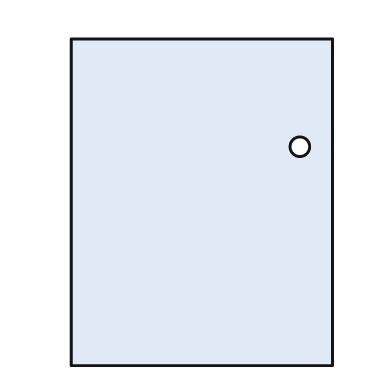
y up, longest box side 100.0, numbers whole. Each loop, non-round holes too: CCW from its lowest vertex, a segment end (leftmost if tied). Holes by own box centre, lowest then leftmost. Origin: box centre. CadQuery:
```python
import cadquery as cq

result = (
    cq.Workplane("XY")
    .moveTo(-40.0, -50.0)
    .lineTo(40.0, -50.0)
    .lineTo(40.0, 50.0)
    .lineTo(-40.0, 50.0)
    .close()
    .moveTo(30.0, 17.0)
    .circle(3.0)
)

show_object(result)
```